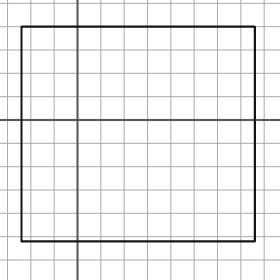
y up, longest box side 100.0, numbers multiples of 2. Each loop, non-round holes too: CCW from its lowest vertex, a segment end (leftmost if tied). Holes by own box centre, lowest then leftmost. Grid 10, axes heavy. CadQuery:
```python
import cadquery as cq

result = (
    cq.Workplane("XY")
    .moveTo(-24.0, -52.0)
    .lineTo(76.0, -52.0)
    .lineTo(76.0, 40.0)
    .lineTo(-24.0, 40.0)
    .close()
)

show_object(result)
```